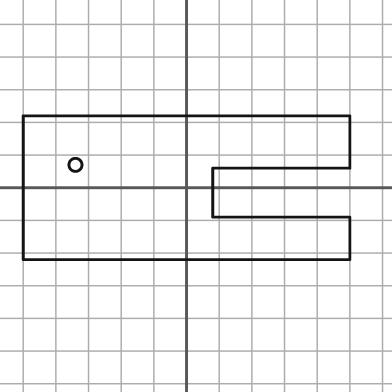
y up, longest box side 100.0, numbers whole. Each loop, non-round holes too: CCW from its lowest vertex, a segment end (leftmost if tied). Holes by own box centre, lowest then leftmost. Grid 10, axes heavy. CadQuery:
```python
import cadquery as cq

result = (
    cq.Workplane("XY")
    .moveTo(-50.0, -22.0)
    .lineTo(50.0, -22.0)
    .lineTo(50.0, -9.0)
    .lineTo(8.0, -9.0)
    .lineTo(8.0, 6.0)
    .lineTo(50.0, 6.0)
    .lineTo(50.0, 22.0)
    .lineTo(-50.0, 22.0)
    .close()
    .moveTo(-34.0, 7.0)
    .circle(2.0)
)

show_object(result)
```